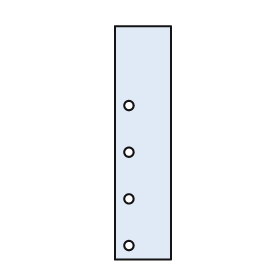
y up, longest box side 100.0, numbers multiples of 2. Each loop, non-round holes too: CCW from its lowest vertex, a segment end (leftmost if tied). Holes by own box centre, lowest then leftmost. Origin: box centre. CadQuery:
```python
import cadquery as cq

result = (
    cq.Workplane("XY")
    .moveTo(-12.0, -50.0)
    .lineTo(12.0, -50.0)
    .lineTo(12.0, 50.0)
    .lineTo(-12.0, 50.0)
    .close()
    .moveTo(-6.0, -44.0)
    .circle(2.0)
    .moveTo(-6.0, -24.0)
    .circle(2.0)
    .moveTo(-6.0, -4.0)
    .circle(2.0)
    .moveTo(-6.0, 16.0)
    .circle(2.0)
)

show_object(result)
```